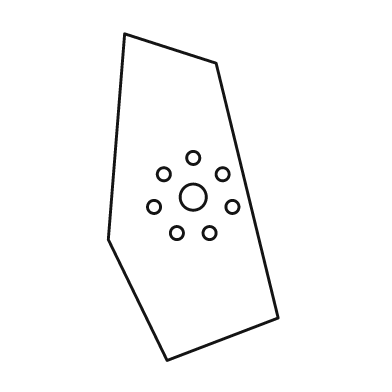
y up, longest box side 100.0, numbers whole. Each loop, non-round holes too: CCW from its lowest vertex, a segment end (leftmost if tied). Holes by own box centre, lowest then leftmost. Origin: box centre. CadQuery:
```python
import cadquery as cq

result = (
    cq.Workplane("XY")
    .moveTo(-8.0, -50.0)
    .lineTo(26.0, -37.0)
    .lineTo(7.0, 41.0)
    .lineTo(-21.0, 50.0)
    .lineTo(-26.0, -13.0)
    .close()
    .moveTo(-5.0, -11.0)
    .circle(2.0)
    .moveTo(5.0, -11.0)
    .circle(2.0)
    .moveTo(-12.0, -3.0)
    .circle(2.0)
    .moveTo(12.0, -3.0)
    .circle(2.0)
    .moveTo(0.0, 0.0)
    .circle(4.0)
    .moveTo(-9.0, 7.0)
    .circle(2.0)
    .moveTo(9.0, 7.0)
    .circle(2.0)
    .moveTo(0.0, 12.0)
    .circle(2.0)
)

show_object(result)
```